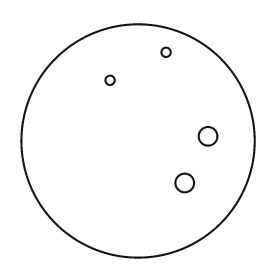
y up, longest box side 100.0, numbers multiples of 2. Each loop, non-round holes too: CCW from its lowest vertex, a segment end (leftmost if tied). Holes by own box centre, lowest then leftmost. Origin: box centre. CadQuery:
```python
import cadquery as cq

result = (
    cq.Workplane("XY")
    .moveTo(0.0, 0.0)
    .circle(50.0)
    .moveTo(20.0, -18.0)
    .circle(4.0)
    .moveTo(30.0, 2.0)
    .circle(4.0)
    .moveTo(-12.0, 26.0)
    .circle(2.0)
    .moveTo(12.0, 38.0)
    .circle(2.0)
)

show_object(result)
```